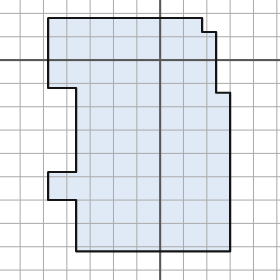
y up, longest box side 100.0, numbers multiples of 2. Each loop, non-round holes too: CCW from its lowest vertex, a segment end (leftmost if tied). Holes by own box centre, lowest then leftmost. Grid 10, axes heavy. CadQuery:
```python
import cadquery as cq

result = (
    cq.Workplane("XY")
    .moveTo(-36.0, -82.0)
    .lineTo(30.0, -82.0)
    .lineTo(30.0, -14.0)
    .lineTo(24.0, -14.0)
    .lineTo(24.0, 12.0)
    .lineTo(18.0, 12.0)
    .lineTo(18.0, 18.0)
    .lineTo(-48.0, 18.0)
    .lineTo(-48.0, -12.0)
    .lineTo(-36.0, -12.0)
    .lineTo(-36.0, -48.0)
    .lineTo(-48.0, -48.0)
    .lineTo(-48.0, -60.0)
    .lineTo(-36.0, -60.0)
    .close()
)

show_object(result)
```